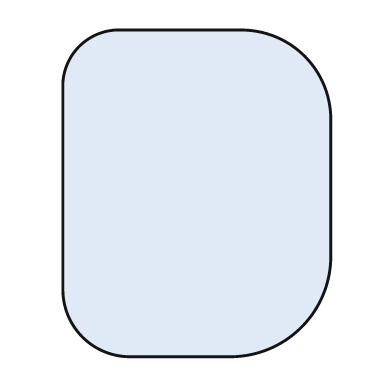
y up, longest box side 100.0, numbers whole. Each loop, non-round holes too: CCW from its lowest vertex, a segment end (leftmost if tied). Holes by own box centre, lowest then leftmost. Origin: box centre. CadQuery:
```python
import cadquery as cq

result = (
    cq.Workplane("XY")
    .moveTo(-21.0, -50.0)
    .lineTo(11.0, -50.0)
    .threePointArc((32.0, -41.0), (41.0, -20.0))
    .lineTo(41.0, 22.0)
    .threePointArc((33.0, 42.0), (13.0, 50.0))
    .lineTo(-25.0, 50.0)
    .threePointArc((-36.0, 45.0), (-41.0, 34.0))
    .lineTo(-41.0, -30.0)
    .threePointArc((-35.0, -44.0), (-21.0, -50.0))
    .close()
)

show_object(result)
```